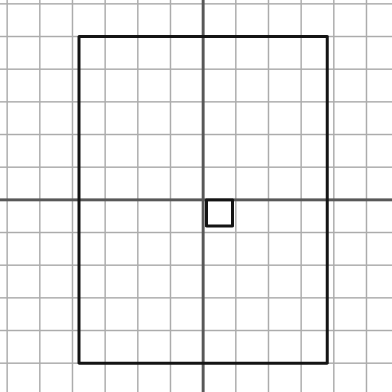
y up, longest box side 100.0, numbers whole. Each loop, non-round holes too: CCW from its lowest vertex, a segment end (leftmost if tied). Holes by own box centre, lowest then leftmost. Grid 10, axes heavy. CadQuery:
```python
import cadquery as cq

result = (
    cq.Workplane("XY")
    .moveTo(-38.0, -50.0)
    .lineTo(38.0, -50.0)
    .lineTo(38.0, 50.0)
    .lineTo(-38.0, 50.0)
    .close()
    .moveTo(1.0, -8.0)
    .lineTo(9.0, -8.0)
    .lineTo(9.0, 0.0)
    .lineTo(1.0, 0.0)
    .close()
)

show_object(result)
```